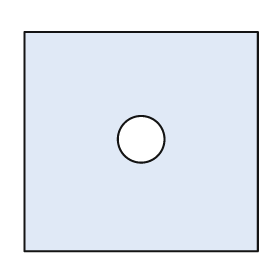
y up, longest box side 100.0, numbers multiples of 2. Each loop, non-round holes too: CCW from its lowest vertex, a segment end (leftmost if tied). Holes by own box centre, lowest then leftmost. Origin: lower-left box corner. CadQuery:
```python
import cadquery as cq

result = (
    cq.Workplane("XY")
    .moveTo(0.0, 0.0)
    .lineTo(100.0, 0.0)
    .lineTo(100.0, 94.0)
    .lineTo(0.0, 94.0)
    .close()
    .moveTo(50.0, 48.0)
    .circle(10.0)
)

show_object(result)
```